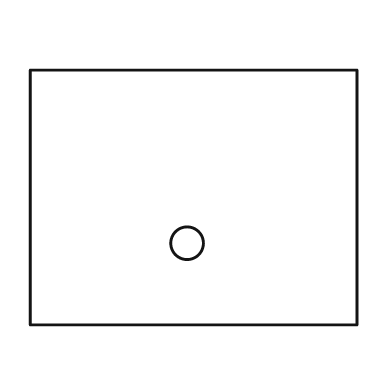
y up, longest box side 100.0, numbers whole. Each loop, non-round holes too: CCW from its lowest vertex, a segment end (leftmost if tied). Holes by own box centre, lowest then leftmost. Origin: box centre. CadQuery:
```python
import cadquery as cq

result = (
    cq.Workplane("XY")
    .moveTo(-50.0, -39.0)
    .lineTo(50.0, -39.0)
    .lineTo(50.0, 39.0)
    .lineTo(-50.0, 39.0)
    .close()
    .moveTo(-2.0, -14.0)
    .circle(5.0)
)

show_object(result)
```